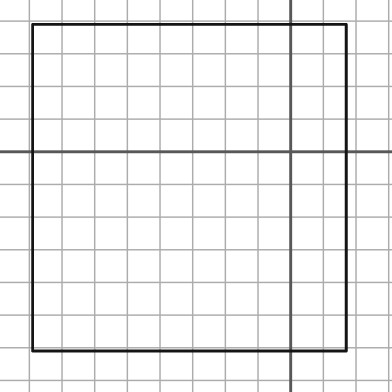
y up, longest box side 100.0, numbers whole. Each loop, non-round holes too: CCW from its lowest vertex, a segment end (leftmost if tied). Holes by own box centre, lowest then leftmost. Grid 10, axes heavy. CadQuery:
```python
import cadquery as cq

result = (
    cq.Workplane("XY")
    .moveTo(-79.0, -61.0)
    .lineTo(17.0, -61.0)
    .lineTo(17.0, 39.0)
    .lineTo(-79.0, 39.0)
    .close()
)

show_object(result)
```